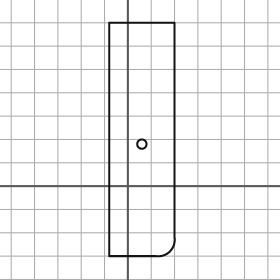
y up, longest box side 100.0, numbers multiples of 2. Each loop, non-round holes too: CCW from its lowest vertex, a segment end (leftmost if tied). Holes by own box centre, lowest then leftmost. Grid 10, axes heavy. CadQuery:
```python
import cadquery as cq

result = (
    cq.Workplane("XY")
    .moveTo(-8.0, -30.0)
    .lineTo(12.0, -30.0)
    .threePointArc((18.0, -28.0), (20.0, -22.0))
    .lineTo(20.0, 70.0)
    .lineTo(-8.0, 70.0)
    .close()
    .moveTo(6.0, 18.0)
    .circle(2.0)
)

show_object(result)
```